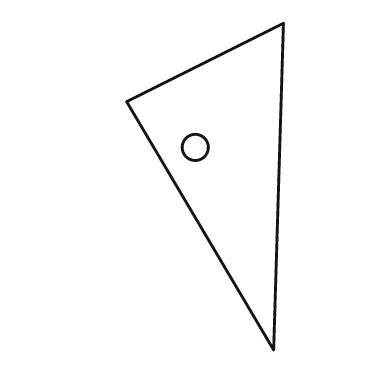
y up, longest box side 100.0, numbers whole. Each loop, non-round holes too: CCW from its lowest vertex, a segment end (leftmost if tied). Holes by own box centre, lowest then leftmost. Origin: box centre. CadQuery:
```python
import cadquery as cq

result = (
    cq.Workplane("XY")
    .moveTo(21.0, -50.0)
    .lineTo(24.0, 50.0)
    .lineTo(-24.0, 26.0)
    .close()
    .moveTo(-3.0, 12.0)
    .circle(4.0)
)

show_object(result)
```